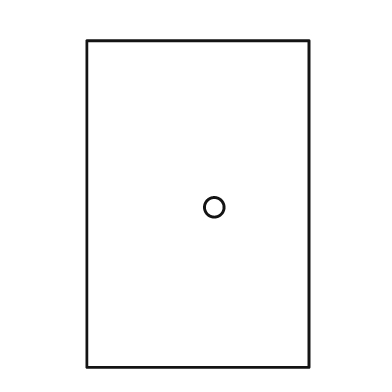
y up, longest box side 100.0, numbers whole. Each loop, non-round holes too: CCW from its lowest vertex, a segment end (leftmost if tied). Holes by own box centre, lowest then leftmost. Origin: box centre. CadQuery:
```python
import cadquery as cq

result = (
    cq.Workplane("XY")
    .moveTo(-34.0, -50.0)
    .lineTo(34.0, -50.0)
    .lineTo(34.0, 50.0)
    .lineTo(-34.0, 50.0)
    .close()
    .moveTo(5.0, -1.0)
    .circle(3.0)
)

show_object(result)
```